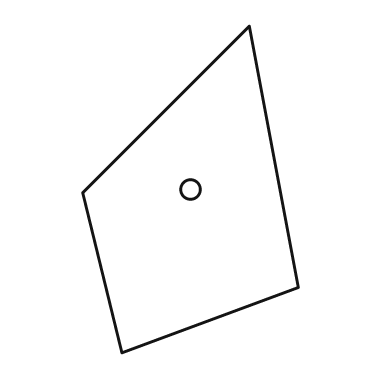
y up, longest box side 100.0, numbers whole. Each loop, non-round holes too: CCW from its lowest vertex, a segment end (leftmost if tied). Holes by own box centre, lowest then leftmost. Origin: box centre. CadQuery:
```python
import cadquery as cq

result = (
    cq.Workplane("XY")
    .moveTo(-21.0, -50.0)
    .lineTo(33.0, -30.0)
    .lineTo(18.0, 50.0)
    .lineTo(-33.0, -1.0)
    .close()
    .moveTo(0.0, 0.0)
    .circle(3.0)
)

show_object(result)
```